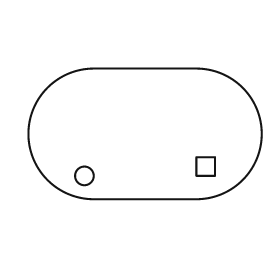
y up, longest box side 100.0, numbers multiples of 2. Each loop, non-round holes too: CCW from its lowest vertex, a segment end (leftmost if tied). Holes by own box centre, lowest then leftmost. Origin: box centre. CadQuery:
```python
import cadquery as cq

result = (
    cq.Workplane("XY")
    .moveTo(-22.0, -28.0)
    .lineTo(22.0, -28.0)
    .threePointArc((50.0, 0.0), (22.0, 28.0))
    .lineTo(-22.0, 28.0)
    .threePointArc((-50.0, 0.0), (-22.0, -28.0))
    .close()
    .moveTo(-26.0, -18.0)
    .circle(4.0)
    .moveTo(22.0, -18.0)
    .lineTo(30.0, -18.0)
    .lineTo(30.0, -10.0)
    .lineTo(22.0, -10.0)
    .close()
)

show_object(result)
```